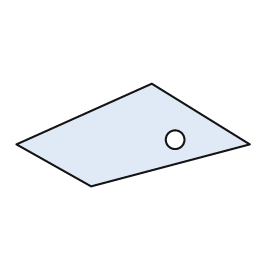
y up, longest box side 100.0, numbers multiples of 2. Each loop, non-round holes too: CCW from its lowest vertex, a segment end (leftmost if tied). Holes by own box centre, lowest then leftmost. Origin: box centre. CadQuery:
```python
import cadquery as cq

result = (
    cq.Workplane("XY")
    .moveTo(-18.0, -22.0)
    .lineTo(50.0, -4.0)
    .lineTo(8.0, 22.0)
    .lineTo(-50.0, -4.0)
    .close()
    .moveTo(18.0, -2.0)
    .circle(4.0)
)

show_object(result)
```